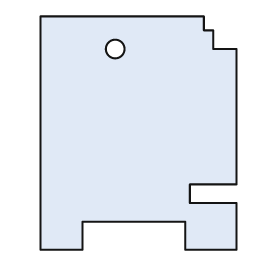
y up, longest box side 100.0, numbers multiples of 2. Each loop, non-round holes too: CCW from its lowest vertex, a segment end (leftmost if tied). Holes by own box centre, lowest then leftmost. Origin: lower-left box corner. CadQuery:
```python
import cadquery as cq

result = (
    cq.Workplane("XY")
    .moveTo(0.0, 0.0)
    .lineTo(18.0, 0.0)
    .lineTo(18.0, 12.0)
    .lineTo(62.0, 12.0)
    .lineTo(62.0, 0.0)
    .lineTo(84.0, 0.0)
    .lineTo(84.0, 20.0)
    .lineTo(64.0, 20.0)
    .lineTo(64.0, 28.0)
    .lineTo(84.0, 28.0)
    .lineTo(84.0, 86.0)
    .lineTo(74.0, 86.0)
    .lineTo(74.0, 94.0)
    .lineTo(70.0, 94.0)
    .lineTo(70.0, 100.0)
    .lineTo(0.0, 100.0)
    .close()
    .moveTo(32.0, 86.0)
    .circle(4.0)
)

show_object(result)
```